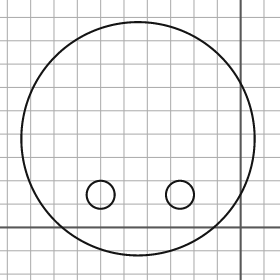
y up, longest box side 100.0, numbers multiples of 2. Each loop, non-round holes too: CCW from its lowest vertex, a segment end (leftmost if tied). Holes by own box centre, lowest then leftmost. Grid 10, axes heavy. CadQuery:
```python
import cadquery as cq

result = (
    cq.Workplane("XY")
    .moveTo(-44.0, 38.0)
    .circle(50.0)
    .moveTo(-60.0, 14.0)
    .circle(6.0)
    .moveTo(-26.0, 14.0)
    .circle(6.0)
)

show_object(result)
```